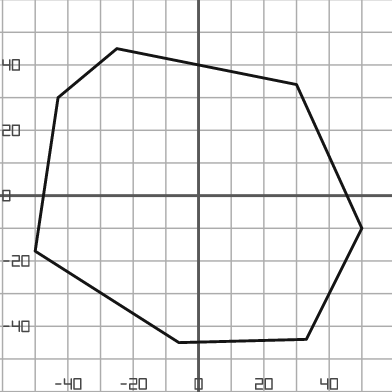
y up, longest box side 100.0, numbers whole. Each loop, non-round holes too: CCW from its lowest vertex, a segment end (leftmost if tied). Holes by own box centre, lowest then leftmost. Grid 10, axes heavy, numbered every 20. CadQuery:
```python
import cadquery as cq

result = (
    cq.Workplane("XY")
    .moveTo(-6.0, -45.0)
    .lineTo(33.0, -44.0)
    .lineTo(50.0, -10.0)
    .lineTo(30.0, 34.0)
    .lineTo(-25.0, 45.0)
    .lineTo(-43.0, 30.0)
    .lineTo(-50.0, -17.0)
    .close()
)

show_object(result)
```